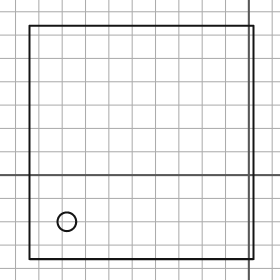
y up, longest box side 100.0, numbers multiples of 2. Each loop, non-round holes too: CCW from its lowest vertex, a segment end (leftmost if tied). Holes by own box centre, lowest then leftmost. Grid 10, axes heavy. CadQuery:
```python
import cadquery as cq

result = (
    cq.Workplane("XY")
    .moveTo(-94.0, -36.0)
    .lineTo(2.0, -36.0)
    .lineTo(2.0, 64.0)
    .lineTo(-94.0, 64.0)
    .close()
    .moveTo(-78.0, -20.0)
    .circle(4.0)
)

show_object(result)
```